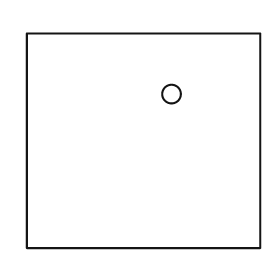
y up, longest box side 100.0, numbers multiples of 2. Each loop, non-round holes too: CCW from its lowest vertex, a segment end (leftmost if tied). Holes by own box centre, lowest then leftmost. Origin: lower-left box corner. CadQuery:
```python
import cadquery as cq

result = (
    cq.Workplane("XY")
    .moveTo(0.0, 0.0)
    .lineTo(100.0, 0.0)
    .lineTo(100.0, 92.0)
    .lineTo(0.0, 92.0)
    .close()
    .moveTo(62.0, 66.0)
    .circle(4.0)
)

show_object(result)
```